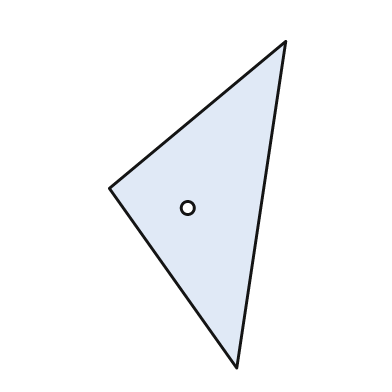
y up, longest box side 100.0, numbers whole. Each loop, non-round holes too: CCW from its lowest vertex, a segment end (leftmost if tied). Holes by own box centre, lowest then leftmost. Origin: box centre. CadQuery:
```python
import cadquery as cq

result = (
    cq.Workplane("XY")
    .moveTo(12.0, -50.0)
    .lineTo(27.0, 50.0)
    .lineTo(-27.0, 5.0)
    .close()
    .moveTo(-3.0, -1.0)
    .circle(2.0)
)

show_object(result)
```